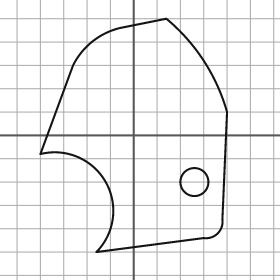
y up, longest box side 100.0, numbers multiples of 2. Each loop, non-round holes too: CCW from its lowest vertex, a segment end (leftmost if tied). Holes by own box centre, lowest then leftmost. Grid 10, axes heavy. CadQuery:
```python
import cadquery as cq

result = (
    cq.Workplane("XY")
    .moveTo(-16.0, -50.0)
    .lineTo(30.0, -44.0)
    .threePointArc((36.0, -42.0), (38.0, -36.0))
    .lineTo(40.0, 10.0)
    .threePointArc((30.0, 32.0), (14.0, 50.0))
    .lineTo(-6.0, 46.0)
    .threePointArc((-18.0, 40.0), (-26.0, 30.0))
    .lineTo(-40.0, -8.0)
    .threePointArc((-12.0, -20.0), (-16.0, -50.0))
    .close()
    .moveTo(26.0, -20.0)
    .circle(6.0)
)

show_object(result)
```